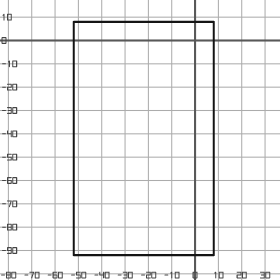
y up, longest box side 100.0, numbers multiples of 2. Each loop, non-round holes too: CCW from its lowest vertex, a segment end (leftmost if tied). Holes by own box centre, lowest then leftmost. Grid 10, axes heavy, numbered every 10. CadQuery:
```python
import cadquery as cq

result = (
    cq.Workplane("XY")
    .moveTo(-52.0, -92.0)
    .lineTo(8.0, -92.0)
    .lineTo(8.0, 8.0)
    .lineTo(-52.0, 8.0)
    .close()
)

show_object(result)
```